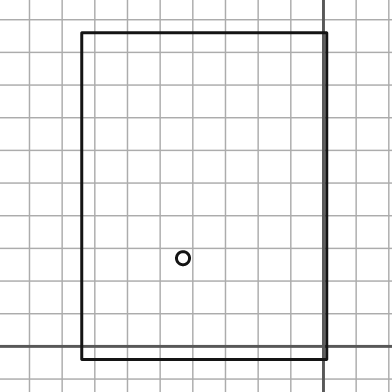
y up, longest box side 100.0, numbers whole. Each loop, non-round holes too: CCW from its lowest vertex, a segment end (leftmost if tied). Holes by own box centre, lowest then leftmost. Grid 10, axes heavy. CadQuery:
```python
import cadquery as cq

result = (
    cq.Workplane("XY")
    .moveTo(-74.0, -4.0)
    .lineTo(1.0, -4.0)
    .lineTo(1.0, 96.0)
    .lineTo(-74.0, 96.0)
    .close()
    .moveTo(-43.0, 27.0)
    .circle(2.0)
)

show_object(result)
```